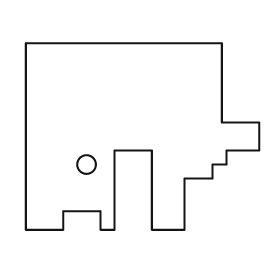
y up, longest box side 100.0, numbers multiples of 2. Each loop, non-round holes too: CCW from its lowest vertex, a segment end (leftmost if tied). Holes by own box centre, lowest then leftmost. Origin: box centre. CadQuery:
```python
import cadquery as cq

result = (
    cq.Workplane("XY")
    .moveTo(-50.0, -40.0)
    .lineTo(-34.0, -40.0)
    .lineTo(-34.0, -32.0)
    .lineTo(-18.0, -32.0)
    .lineTo(-18.0, -40.0)
    .lineTo(-12.0, -40.0)
    .lineTo(-12.0, -6.0)
    .lineTo(4.0, -6.0)
    .lineTo(4.0, -40.0)
    .lineTo(18.0, -40.0)
    .lineTo(18.0, -18.0)
    .lineTo(30.0, -18.0)
    .lineTo(30.0, -12.0)
    .lineTo(36.0, -12.0)
    .lineTo(36.0, -6.0)
    .lineTo(50.0, -6.0)
    .lineTo(50.0, 6.0)
    .lineTo(34.0, 6.0)
    .lineTo(34.0, 40.0)
    .lineTo(-50.0, 40.0)
    .close()
    .moveTo(-24.0, -12.0)
    .circle(4.0)
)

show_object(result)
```